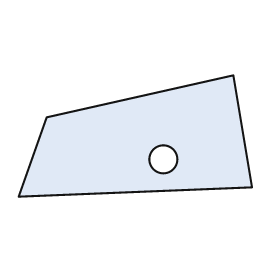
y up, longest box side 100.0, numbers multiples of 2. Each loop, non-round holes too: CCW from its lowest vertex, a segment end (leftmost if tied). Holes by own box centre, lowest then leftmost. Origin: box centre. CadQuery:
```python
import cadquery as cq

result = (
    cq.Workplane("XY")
    .moveTo(-50.0, -26.0)
    .lineTo(50.0, -22.0)
    .lineTo(42.0, 26.0)
    .lineTo(-38.0, 8.0)
    .close()
    .moveTo(12.0, -10.0)
    .circle(6.0)
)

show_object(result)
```